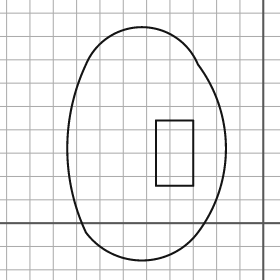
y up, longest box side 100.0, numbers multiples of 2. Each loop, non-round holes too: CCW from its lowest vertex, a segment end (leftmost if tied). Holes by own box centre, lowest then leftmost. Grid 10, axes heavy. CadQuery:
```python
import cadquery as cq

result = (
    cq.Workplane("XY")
    .moveTo(-76.0, -4.0)
    .threePointArc((-52.0, -16.0), (-28.0, -4.0))
    .threePointArc((-16.0, 32.0), (-28.0, 68.0))
    .threePointArc((-52.0, 84.0), (-76.0, 68.0))
    .threePointArc((-84.0, 32.0), (-76.0, -4.0))
    .close()
    .moveTo(-46.0, 16.0)
    .lineTo(-30.0, 16.0)
    .lineTo(-30.0, 44.0)
    .lineTo(-46.0, 44.0)
    .close()
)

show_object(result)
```